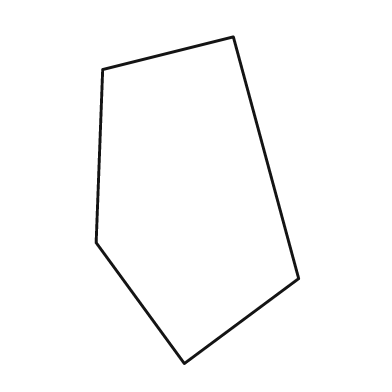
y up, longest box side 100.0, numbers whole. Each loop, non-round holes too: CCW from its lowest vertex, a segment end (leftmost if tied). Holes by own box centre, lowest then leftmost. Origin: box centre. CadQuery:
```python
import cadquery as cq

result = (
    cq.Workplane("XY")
    .moveTo(-4.0, -50.0)
    .lineTo(31.0, -24.0)
    .lineTo(11.0, 50.0)
    .lineTo(-29.0, 40.0)
    .lineTo(-31.0, -13.0)
    .close()
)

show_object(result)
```